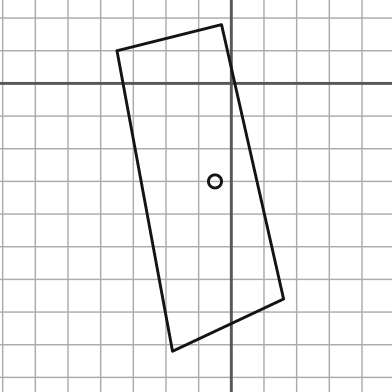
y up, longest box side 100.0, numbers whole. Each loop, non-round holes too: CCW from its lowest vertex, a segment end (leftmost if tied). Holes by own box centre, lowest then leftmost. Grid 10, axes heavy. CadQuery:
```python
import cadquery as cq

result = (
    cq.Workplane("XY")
    .moveTo(-18.0, -82.0)
    .lineTo(16.0, -66.0)
    .lineTo(-3.0, 18.0)
    .lineTo(-35.0, 10.0)
    .close()
    .moveTo(-5.0, -30.0)
    .circle(2.0)
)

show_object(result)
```